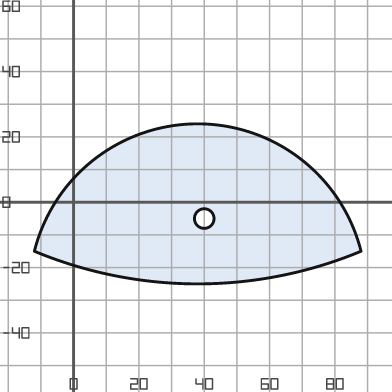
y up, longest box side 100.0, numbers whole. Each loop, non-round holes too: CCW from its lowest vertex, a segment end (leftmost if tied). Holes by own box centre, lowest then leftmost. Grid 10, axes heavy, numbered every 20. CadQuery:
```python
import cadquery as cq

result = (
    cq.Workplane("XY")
    .moveTo(-12.0, -15.0)
    .threePointArc((38.0, -25.0), (88.0, -15.0))
    .threePointArc((38.0, 24.0), (-12.0, -15.0))
    .close()
    .moveTo(40.0, -5.0)
    .circle(3.0)
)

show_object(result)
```